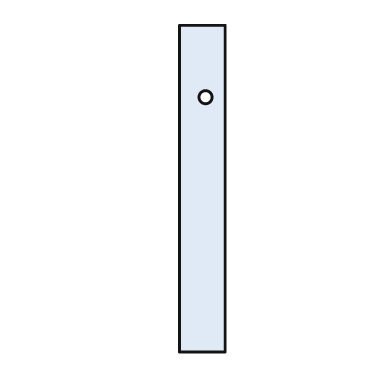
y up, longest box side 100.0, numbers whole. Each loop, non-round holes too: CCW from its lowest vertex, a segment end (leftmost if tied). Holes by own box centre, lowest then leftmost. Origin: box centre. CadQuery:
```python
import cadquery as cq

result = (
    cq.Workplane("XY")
    .moveTo(-7.0, -50.0)
    .lineTo(7.0, -50.0)
    .lineTo(7.0, 50.0)
    .lineTo(-7.0, 50.0)
    .close()
    .moveTo(1.0, 28.0)
    .circle(2.0)
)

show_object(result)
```